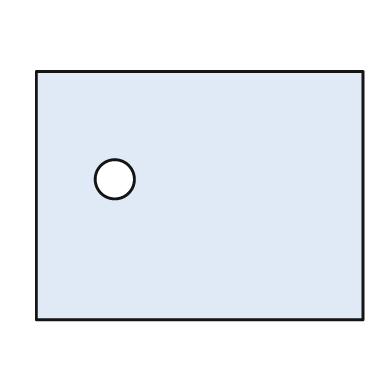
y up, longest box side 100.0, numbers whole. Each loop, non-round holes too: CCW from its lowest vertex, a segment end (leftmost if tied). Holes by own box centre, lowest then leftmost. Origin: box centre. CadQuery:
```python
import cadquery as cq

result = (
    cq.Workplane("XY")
    .moveTo(-50.0, -38.0)
    .lineTo(50.0, -38.0)
    .lineTo(50.0, 38.0)
    .lineTo(-50.0, 38.0)
    .close()
    .moveTo(-26.0, 5.0)
    .circle(6.0)
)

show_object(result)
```